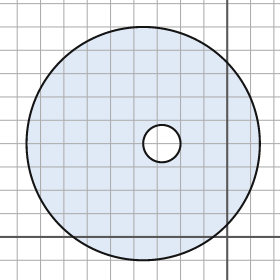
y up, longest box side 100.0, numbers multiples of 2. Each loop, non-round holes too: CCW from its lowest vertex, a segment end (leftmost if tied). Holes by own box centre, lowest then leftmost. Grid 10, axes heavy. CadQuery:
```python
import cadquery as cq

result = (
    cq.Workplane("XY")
    .moveTo(-36.0, 40.0)
    .circle(50.0)
    .moveTo(-28.0, 40.0)
    .circle(8.0)
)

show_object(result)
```